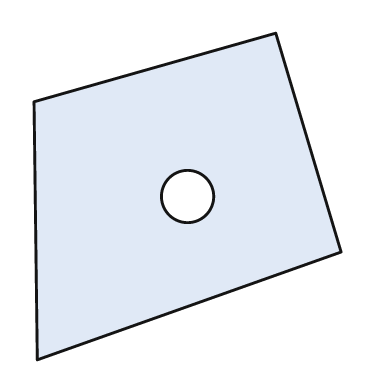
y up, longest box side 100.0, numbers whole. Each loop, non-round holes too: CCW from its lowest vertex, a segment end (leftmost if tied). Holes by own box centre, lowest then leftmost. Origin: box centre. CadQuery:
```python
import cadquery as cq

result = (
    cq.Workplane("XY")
    .moveTo(-46.0, -50.0)
    .lineTo(47.0, -17.0)
    .lineTo(27.0, 50.0)
    .lineTo(-47.0, 29.0)
    .close()
    .moveTo(0.0, 0.0)
    .circle(8.0)
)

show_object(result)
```